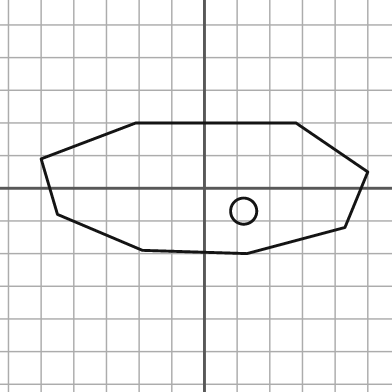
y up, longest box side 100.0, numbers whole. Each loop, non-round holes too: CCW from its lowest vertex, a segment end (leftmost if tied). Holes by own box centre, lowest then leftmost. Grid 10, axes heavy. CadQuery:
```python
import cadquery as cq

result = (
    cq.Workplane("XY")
    .moveTo(13.0, -20.0)
    .lineTo(43.0, -12.0)
    .lineTo(50.0, 5.0)
    .lineTo(28.0, 20.0)
    .lineTo(-21.0, 20.0)
    .lineTo(-50.0, 9.0)
    .lineTo(-45.0, -8.0)
    .lineTo(-19.0, -19.0)
    .close()
    .moveTo(12.0, -7.0)
    .circle(4.0)
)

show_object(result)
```